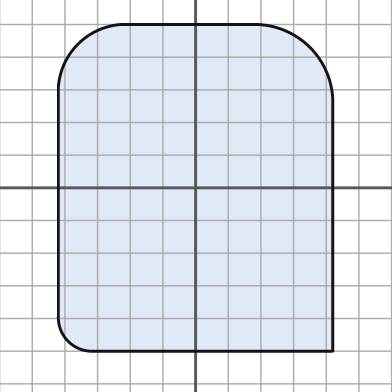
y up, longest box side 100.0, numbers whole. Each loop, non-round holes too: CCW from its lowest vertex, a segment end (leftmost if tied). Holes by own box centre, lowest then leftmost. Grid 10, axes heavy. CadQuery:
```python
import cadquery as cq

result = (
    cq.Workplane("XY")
    .moveTo(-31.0, -50.0)
    .lineTo(42.0, -50.0)
    .lineTo(42.0, 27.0)
    .threePointArc((35.0, 43.0), (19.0, 50.0))
    .lineTo(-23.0, 50.0)
    .threePointArc((-36.0, 44.0), (-42.0, 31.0))
    .lineTo(-42.0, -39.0)
    .threePointArc((-39.0, -47.0), (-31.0, -50.0))
    .close()
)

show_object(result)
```